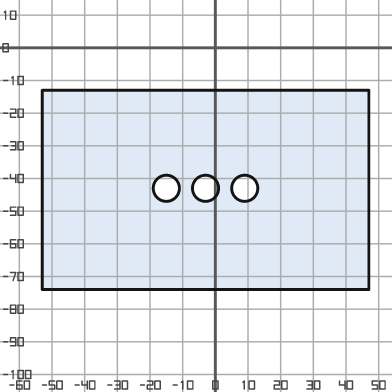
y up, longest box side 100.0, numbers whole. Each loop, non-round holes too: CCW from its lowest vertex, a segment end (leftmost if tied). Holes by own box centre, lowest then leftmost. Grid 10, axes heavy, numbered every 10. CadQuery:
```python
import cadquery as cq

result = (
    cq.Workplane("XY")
    .moveTo(-53.0, -74.0)
    .lineTo(47.0, -74.0)
    .lineTo(47.0, -13.0)
    .lineTo(-53.0, -13.0)
    .close()
    .moveTo(-15.0, -43.0)
    .circle(4.0)
    .moveTo(-3.0, -43.0)
    .circle(4.0)
    .moveTo(9.0, -43.0)
    .circle(4.0)
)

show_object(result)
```